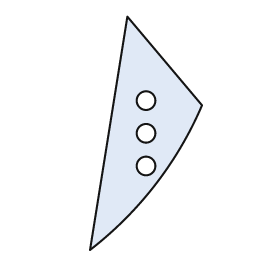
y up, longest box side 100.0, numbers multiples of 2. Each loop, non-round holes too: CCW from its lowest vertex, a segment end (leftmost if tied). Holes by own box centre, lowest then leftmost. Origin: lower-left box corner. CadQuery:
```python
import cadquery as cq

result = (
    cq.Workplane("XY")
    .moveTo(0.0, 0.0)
    .threePointArc((28.0, 28.0), (48.0, 62.0))
    .lineTo(16.0, 100.0)
    .close()
    .moveTo(24.0, 36.0)
    .circle(4.0)
    .moveTo(24.0, 50.0)
    .circle(4.0)
    .moveTo(24.0, 64.0)
    .circle(4.0)
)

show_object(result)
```